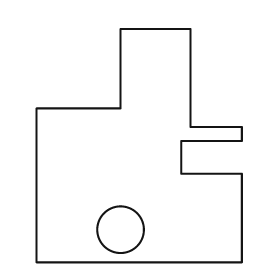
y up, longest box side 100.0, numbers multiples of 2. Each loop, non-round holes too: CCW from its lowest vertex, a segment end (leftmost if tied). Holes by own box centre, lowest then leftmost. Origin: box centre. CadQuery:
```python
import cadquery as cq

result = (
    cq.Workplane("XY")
    .moveTo(-44.0, -50.0)
    .lineTo(44.0, -50.0)
    .lineTo(44.0, -12.0)
    .lineTo(18.0, -12.0)
    .lineTo(18.0, 2.0)
    .lineTo(44.0, 2.0)
    .lineTo(44.0, 8.0)
    .lineTo(22.0, 8.0)
    .lineTo(22.0, 50.0)
    .lineTo(-8.0, 50.0)
    .lineTo(-8.0, 16.0)
    .lineTo(-44.0, 16.0)
    .close()
    .moveTo(-8.0, -36.0)
    .circle(10.0)
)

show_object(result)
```